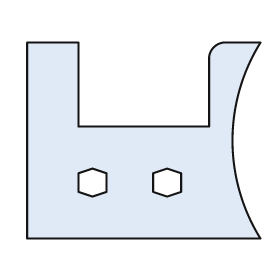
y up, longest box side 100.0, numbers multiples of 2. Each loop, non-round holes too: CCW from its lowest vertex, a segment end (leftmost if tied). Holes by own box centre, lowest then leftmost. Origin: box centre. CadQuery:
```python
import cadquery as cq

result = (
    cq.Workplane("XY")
    .moveTo(-50.0, -42.0)
    .lineTo(50.0, -42.0)
    .threePointArc((38.0, 0.0), (50.0, 42.0))
    .lineTo(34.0, 42.0)
    .threePointArc((30.0, 40.0), (28.0, 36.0))
    .lineTo(28.0, 6.0)
    .lineTo(-28.0, 6.0)
    .lineTo(-28.0, 42.0)
    .lineTo(-50.0, 42.0)
    .close()
    .moveTo(-22.0, -24.0)
    .lineTo(-16.0, -22.0)
    .lineTo(-16.0, -14.0)
    .lineTo(-22.0, -12.0)
    .lineTo(-28.0, -14.0)
    .lineTo(-28.0, -22.0)
    .close()
    .moveTo(10.0, -24.0)
    .lineTo(16.0, -22.0)
    .lineTo(16.0, -14.0)
    .lineTo(10.0, -12.0)
    .lineTo(4.0, -14.0)
    .lineTo(4.0, -22.0)
    .close()
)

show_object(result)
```